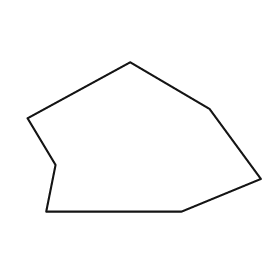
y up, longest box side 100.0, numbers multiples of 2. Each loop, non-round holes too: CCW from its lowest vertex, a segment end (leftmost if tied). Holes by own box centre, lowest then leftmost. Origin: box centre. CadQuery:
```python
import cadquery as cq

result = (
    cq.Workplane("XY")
    .moveTo(-42.0, -32.0)
    .lineTo(16.0, -32.0)
    .lineTo(50.0, -18.0)
    .lineTo(28.0, 12.0)
    .lineTo(-6.0, 32.0)
    .lineTo(-50.0, 8.0)
    .lineTo(-38.0, -12.0)
    .close()
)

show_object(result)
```